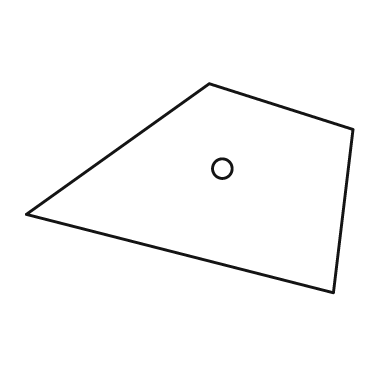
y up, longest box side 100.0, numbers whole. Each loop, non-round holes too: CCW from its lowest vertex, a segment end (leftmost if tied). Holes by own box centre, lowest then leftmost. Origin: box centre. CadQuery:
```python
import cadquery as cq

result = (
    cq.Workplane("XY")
    .moveTo(44.0, -32.0)
    .lineTo(50.0, 18.0)
    .lineTo(6.0, 32.0)
    .lineTo(-50.0, -8.0)
    .close()
    .moveTo(10.0, 6.0)
    .circle(3.0)
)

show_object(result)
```